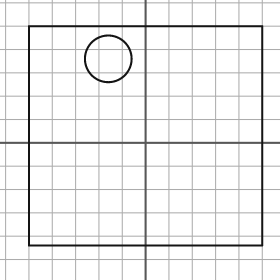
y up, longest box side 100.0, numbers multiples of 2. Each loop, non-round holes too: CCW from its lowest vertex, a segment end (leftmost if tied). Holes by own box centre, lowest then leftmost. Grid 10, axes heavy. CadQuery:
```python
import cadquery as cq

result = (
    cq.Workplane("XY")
    .moveTo(-50.0, -44.0)
    .lineTo(50.0, -44.0)
    .lineTo(50.0, 50.0)
    .lineTo(-50.0, 50.0)
    .close()
    .moveTo(-16.0, 36.0)
    .circle(10.0)
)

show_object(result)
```